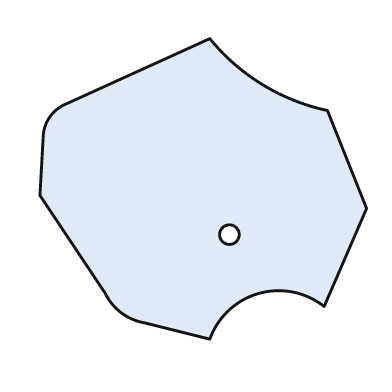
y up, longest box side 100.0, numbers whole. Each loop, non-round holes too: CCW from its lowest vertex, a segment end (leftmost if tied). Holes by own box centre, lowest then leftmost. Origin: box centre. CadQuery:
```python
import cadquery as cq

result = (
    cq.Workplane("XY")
    .moveTo(2.0, -46.0)
    .threePointArc((17.0, -32.0), (37.0, -36.0))
    .lineTo(50.0, -6.0)
    .lineTo(38.0, 24.0)
    .threePointArc((18.0, 32.0), (2.0, 46.0))
    .lineTo(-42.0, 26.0)
    .threePointArc((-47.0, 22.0), (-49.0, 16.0))
    .lineTo(-50.0, -2.0)
    .lineTo(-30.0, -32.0)
    .threePointArc((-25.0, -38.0), (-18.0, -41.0))
    .close()
    .moveTo(8.0, -14.0)
    .circle(3.0)
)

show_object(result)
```